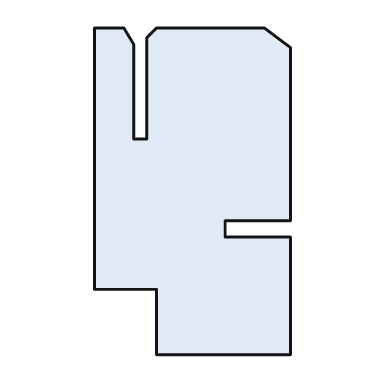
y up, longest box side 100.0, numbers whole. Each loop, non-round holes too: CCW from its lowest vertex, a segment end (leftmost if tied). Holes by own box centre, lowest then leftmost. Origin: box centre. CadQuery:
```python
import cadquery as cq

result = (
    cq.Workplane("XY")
    .moveTo(-11.0, -50.0)
    .lineTo(30.0, -50.0)
    .lineTo(30.0, -14.0)
    .lineTo(10.0, -14.0)
    .lineTo(10.0, -9.0)
    .lineTo(30.0, -9.0)
    .lineTo(30.0, 44.0)
    .lineTo(22.0, 50.0)
    .lineTo(-11.0, 50.0)
    .lineTo(-14.0, 47.0)
    .lineTo(-14.0, 16.0)
    .lineTo(-18.0, 16.0)
    .lineTo(-18.0, 45.0)
    .lineTo(-21.0, 50.0)
    .lineTo(-30.0, 50.0)
    .lineTo(-30.0, -30.0)
    .lineTo(-11.0, -30.0)
    .close()
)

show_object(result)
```